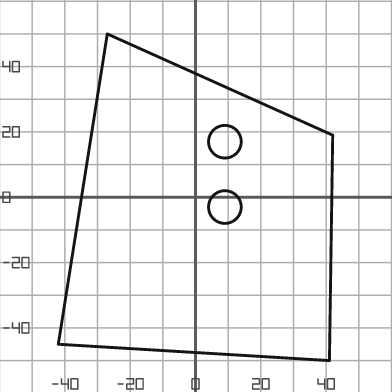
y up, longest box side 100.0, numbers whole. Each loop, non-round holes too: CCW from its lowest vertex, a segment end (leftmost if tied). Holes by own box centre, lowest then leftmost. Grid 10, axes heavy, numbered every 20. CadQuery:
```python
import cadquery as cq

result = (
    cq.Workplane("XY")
    .moveTo(41.0, -50.0)
    .lineTo(42.0, 19.0)
    .lineTo(-27.0, 50.0)
    .lineTo(-42.0, -45.0)
    .close()
    .moveTo(9.0, -3.0)
    .circle(5.0)
    .moveTo(9.0, 17.0)
    .circle(5.0)
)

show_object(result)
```